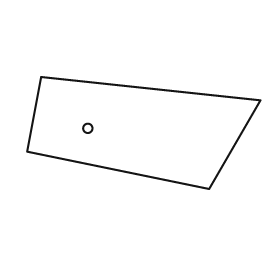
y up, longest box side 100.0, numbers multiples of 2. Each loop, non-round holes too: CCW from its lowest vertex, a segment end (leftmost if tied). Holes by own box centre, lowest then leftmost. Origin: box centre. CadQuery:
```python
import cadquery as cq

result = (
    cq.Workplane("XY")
    .moveTo(28.0, -24.0)
    .lineTo(50.0, 14.0)
    .lineTo(-44.0, 24.0)
    .lineTo(-50.0, -8.0)
    .close()
    .moveTo(-24.0, 2.0)
    .circle(2.0)
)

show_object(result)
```